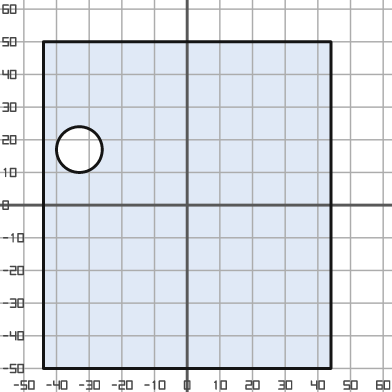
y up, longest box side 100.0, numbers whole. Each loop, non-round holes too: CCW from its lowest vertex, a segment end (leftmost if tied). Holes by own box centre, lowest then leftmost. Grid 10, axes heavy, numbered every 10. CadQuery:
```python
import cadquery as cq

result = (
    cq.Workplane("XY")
    .moveTo(-44.0, -50.0)
    .lineTo(44.0, -50.0)
    .lineTo(44.0, 50.0)
    .lineTo(-44.0, 50.0)
    .close()
    .moveTo(-33.0, 17.0)
    .circle(7.0)
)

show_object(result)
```